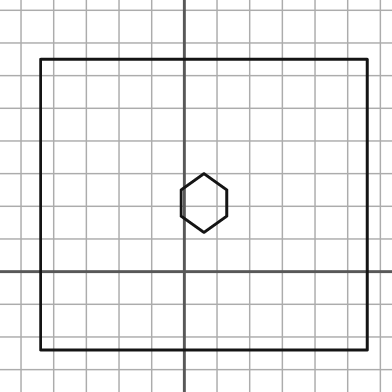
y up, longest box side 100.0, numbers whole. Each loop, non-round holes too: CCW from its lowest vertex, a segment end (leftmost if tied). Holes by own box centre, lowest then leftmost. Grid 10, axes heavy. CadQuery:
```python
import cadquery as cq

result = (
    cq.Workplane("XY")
    .moveTo(-44.0, -24.0)
    .lineTo(56.0, -24.0)
    .lineTo(56.0, 65.0)
    .lineTo(-44.0, 65.0)
    .close()
    .moveTo(6.0, 12.0)
    .lineTo(13.0, 17.0)
    .lineTo(13.0, 25.0)
    .lineTo(6.0, 30.0)
    .lineTo(-1.0, 25.0)
    .lineTo(-1.0, 17.0)
    .close()
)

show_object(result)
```